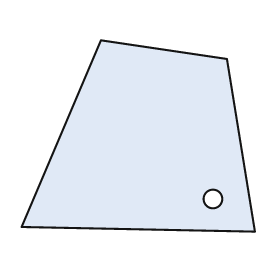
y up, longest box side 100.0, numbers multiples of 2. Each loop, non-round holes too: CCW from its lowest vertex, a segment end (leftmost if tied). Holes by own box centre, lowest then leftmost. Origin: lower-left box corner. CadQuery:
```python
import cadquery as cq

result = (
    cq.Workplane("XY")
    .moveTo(100.0, 0.0)
    .lineTo(88.0, 74.0)
    .lineTo(34.0, 82.0)
    .lineTo(0.0, 2.0)
    .close()
    .moveTo(82.0, 14.0)
    .circle(4.0)
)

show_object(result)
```